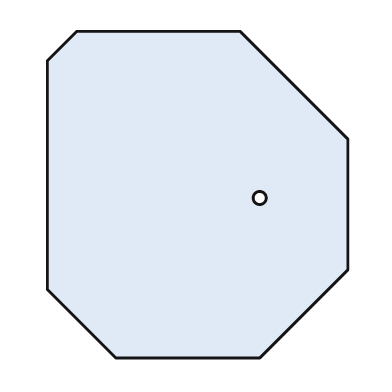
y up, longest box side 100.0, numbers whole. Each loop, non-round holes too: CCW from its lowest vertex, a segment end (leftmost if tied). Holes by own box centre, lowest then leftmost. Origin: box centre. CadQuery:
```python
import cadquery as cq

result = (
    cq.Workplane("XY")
    .moveTo(-25.0, -50.0)
    .lineTo(19.0, -50.0)
    .lineTo(46.0, -23.0)
    .lineTo(46.0, 17.0)
    .lineTo(13.0, 50.0)
    .lineTo(-37.0, 50.0)
    .lineTo(-46.0, 41.0)
    .lineTo(-46.0, -29.0)
    .close()
    .moveTo(19.0, -1.0)
    .circle(2.0)
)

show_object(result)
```